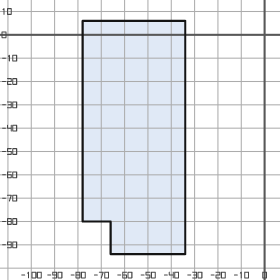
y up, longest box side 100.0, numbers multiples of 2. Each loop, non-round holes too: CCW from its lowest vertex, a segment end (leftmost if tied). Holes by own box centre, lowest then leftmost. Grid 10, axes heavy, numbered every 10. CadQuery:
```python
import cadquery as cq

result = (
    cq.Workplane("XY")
    .moveTo(-66.0, -94.0)
    .lineTo(-34.0, -94.0)
    .lineTo(-34.0, 6.0)
    .lineTo(-78.0, 6.0)
    .lineTo(-78.0, -80.0)
    .lineTo(-66.0, -80.0)
    .close()
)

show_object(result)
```